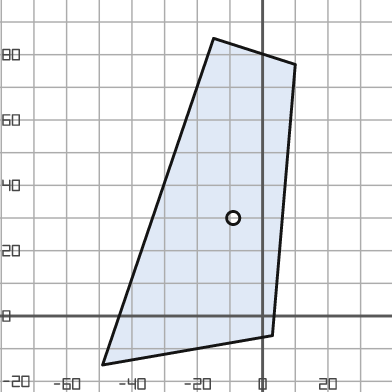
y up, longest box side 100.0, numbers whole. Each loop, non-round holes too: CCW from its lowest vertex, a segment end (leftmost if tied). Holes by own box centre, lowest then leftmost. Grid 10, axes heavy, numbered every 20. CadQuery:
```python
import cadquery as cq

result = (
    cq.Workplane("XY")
    .moveTo(-49.0, -15.0)
    .lineTo(3.0, -6.0)
    .lineTo(10.0, 77.0)
    .lineTo(-15.0, 85.0)
    .close()
    .moveTo(-9.0, 30.0)
    .circle(2.0)
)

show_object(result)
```